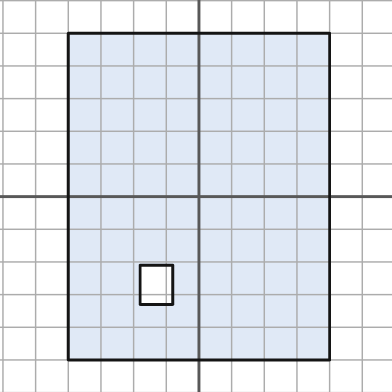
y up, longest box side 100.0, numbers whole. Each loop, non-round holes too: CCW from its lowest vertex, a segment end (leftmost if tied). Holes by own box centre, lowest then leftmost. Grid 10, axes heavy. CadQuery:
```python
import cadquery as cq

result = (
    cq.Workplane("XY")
    .moveTo(-40.0, -50.0)
    .lineTo(40.0, -50.0)
    .lineTo(40.0, 50.0)
    .lineTo(-40.0, 50.0)
    .close()
    .moveTo(-18.0, -33.0)
    .lineTo(-8.0, -33.0)
    .lineTo(-8.0, -21.0)
    .lineTo(-18.0, -21.0)
    .close()
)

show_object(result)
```